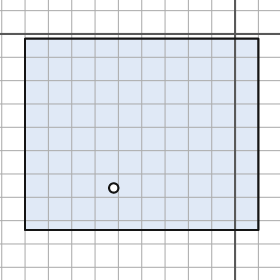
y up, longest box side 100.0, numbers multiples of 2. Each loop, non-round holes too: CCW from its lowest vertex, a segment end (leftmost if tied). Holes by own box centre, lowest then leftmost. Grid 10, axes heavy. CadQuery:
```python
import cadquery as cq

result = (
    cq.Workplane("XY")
    .moveTo(-90.0, -84.0)
    .lineTo(10.0, -84.0)
    .lineTo(10.0, -2.0)
    .lineTo(-90.0, -2.0)
    .close()
    .moveTo(-52.0, -66.0)
    .circle(2.0)
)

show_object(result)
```